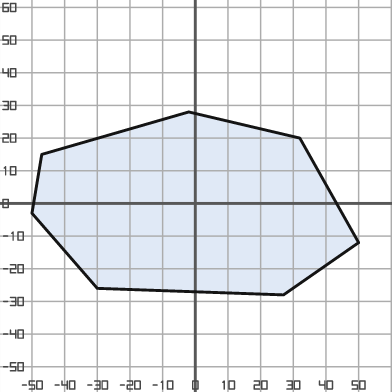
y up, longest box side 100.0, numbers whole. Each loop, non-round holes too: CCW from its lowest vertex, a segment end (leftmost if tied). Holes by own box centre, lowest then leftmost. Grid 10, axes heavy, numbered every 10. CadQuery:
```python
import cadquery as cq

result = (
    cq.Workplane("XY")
    .moveTo(27.0, -28.0)
    .lineTo(50.0, -12.0)
    .lineTo(32.0, 20.0)
    .lineTo(-2.0, 28.0)
    .lineTo(-47.0, 15.0)
    .lineTo(-50.0, -3.0)
    .lineTo(-30.0, -26.0)
    .close()
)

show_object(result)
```